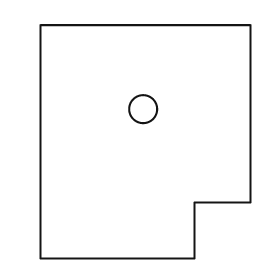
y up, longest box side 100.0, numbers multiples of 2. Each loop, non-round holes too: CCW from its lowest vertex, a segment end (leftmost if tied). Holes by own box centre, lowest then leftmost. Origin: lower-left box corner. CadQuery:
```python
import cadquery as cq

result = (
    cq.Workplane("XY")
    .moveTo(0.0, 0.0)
    .lineTo(66.0, 0.0)
    .lineTo(66.0, 24.0)
    .lineTo(90.0, 24.0)
    .lineTo(90.0, 100.0)
    .lineTo(0.0, 100.0)
    .close()
    .moveTo(44.0, 64.0)
    .circle(6.0)
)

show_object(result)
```